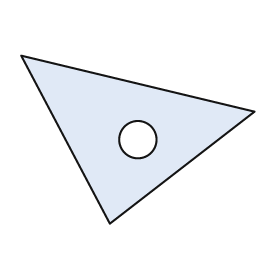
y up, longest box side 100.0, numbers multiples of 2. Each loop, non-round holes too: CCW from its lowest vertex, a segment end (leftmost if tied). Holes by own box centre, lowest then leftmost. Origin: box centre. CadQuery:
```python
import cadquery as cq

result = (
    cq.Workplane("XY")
    .moveTo(-12.0, -36.0)
    .lineTo(50.0, 12.0)
    .lineTo(-50.0, 36.0)
    .close()
    .moveTo(0.0, 0.0)
    .circle(8.0)
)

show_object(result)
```